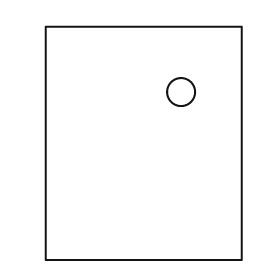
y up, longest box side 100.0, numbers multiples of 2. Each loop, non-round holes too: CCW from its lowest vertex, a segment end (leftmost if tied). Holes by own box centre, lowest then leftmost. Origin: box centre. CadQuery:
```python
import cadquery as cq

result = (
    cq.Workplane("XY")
    .moveTo(-42.0, -50.0)
    .lineTo(42.0, -50.0)
    .lineTo(42.0, 50.0)
    .lineTo(-42.0, 50.0)
    .close()
    .moveTo(16.0, 22.0)
    .circle(6.0)
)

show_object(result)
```